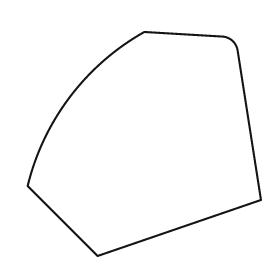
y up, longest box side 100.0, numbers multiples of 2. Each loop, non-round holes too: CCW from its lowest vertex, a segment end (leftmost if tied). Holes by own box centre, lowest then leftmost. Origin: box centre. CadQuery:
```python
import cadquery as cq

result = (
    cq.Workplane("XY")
    .moveTo(-20.0, -48.0)
    .lineTo(50.0, -24.0)
    .lineTo(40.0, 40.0)
    .threePointArc((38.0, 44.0), (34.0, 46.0))
    .lineTo(0.0, 48.0)
    .threePointArc((-32.0, 20.0), (-50.0, -18.0))
    .close()
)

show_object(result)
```